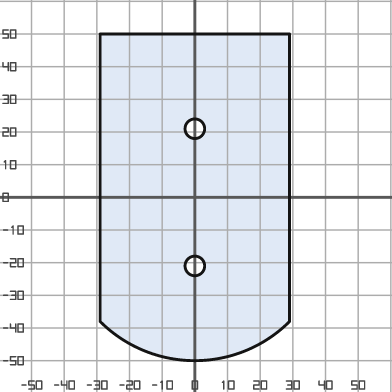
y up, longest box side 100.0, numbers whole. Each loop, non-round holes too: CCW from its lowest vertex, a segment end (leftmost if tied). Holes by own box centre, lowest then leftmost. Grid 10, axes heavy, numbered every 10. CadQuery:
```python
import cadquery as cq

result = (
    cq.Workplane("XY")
    .moveTo(-29.0, -38.0)
    .threePointArc((0.0, -50.0), (29.0, -38.0))
    .lineTo(29.0, 50.0)
    .lineTo(-29.0, 50.0)
    .close()
    .moveTo(0.0, -21.0)
    .circle(3.0)
    .moveTo(0.0, 21.0)
    .circle(3.0)
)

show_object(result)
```